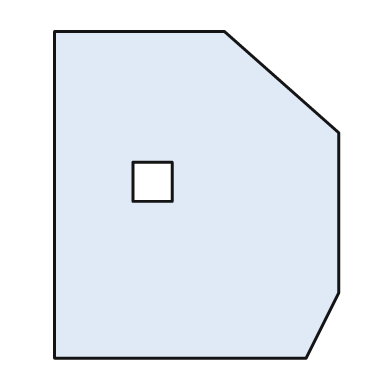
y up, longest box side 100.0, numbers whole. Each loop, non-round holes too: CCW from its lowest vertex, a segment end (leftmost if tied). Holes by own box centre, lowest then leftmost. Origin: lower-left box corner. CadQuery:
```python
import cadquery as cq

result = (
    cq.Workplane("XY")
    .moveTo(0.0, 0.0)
    .lineTo(77.0, 0.0)
    .lineTo(87.0, 20.0)
    .lineTo(87.0, 69.0)
    .lineTo(52.0, 100.0)
    .lineTo(0.0, 100.0)
    .close()
    .moveTo(24.0, 48.0)
    .lineTo(36.0, 48.0)
    .lineTo(36.0, 60.0)
    .lineTo(24.0, 60.0)
    .close()
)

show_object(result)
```